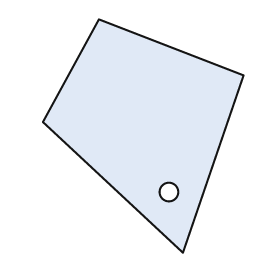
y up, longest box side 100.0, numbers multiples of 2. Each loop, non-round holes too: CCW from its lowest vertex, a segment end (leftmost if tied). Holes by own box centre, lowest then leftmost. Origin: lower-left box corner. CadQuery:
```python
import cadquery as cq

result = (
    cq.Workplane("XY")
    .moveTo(60.0, 0.0)
    .lineTo(86.0, 76.0)
    .lineTo(24.0, 100.0)
    .lineTo(0.0, 56.0)
    .close()
    .moveTo(54.0, 26.0)
    .circle(4.0)
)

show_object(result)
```